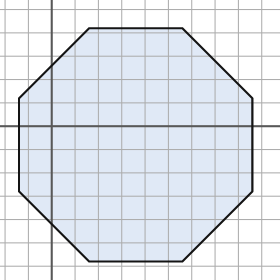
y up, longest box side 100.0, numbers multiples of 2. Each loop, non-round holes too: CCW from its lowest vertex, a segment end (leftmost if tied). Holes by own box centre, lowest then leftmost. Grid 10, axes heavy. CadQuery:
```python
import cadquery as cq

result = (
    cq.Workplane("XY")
    .moveTo(16.0, -58.0)
    .lineTo(56.0, -58.0)
    .lineTo(86.0, -28.0)
    .lineTo(86.0, 12.0)
    .lineTo(56.0, 42.0)
    .lineTo(16.0, 42.0)
    .lineTo(-14.0, 12.0)
    .lineTo(-14.0, -28.0)
    .close()
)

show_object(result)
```